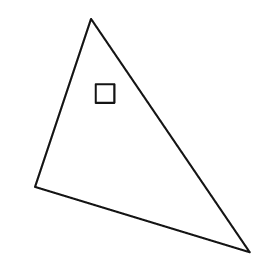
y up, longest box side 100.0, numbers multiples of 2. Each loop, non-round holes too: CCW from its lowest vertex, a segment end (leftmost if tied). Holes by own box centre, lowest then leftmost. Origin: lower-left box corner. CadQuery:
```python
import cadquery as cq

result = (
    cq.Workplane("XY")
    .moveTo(92.0, 0.0)
    .lineTo(24.0, 100.0)
    .lineTo(0.0, 28.0)
    .close()
    .moveTo(26.0, 64.0)
    .lineTo(34.0, 64.0)
    .lineTo(34.0, 72.0)
    .lineTo(26.0, 72.0)
    .close()
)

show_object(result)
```